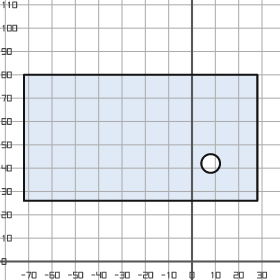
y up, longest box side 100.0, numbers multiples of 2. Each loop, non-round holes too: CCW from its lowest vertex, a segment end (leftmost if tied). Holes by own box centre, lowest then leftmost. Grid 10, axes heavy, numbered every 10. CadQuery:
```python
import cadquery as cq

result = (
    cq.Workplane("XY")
    .moveTo(-72.0, 26.0)
    .lineTo(28.0, 26.0)
    .lineTo(28.0, 80.0)
    .lineTo(-72.0, 80.0)
    .close()
    .moveTo(8.0, 42.0)
    .circle(4.0)
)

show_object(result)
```